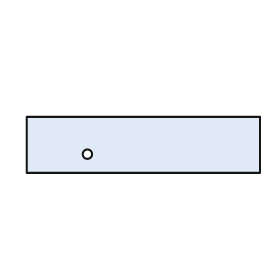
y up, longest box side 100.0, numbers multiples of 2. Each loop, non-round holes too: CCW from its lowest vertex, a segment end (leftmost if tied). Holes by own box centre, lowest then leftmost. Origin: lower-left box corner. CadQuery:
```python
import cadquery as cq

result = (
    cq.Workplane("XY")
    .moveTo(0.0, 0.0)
    .lineTo(100.0, 0.0)
    .lineTo(100.0, 24.0)
    .lineTo(0.0, 24.0)
    .close()
    .moveTo(26.0, 8.0)
    .circle(2.0)
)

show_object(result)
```